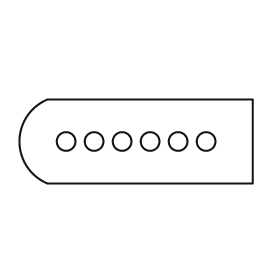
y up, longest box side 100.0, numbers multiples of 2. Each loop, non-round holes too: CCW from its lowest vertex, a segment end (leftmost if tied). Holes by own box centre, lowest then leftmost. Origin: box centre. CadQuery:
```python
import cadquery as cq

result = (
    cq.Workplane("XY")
    .moveTo(-38.0, -18.0)
    .lineTo(50.0, -18.0)
    .lineTo(50.0, 18.0)
    .lineTo(-38.0, 18.0)
    .threePointArc((-50.0, 0.0), (-38.0, -18.0))
    .close()
    .moveTo(-30.0, 0.0)
    .circle(4.0)
    .moveTo(-18.0, 0.0)
    .circle(4.0)
    .moveTo(-6.0, 0.0)
    .circle(4.0)
    .moveTo(6.0, 0.0)
    .circle(4.0)
    .moveTo(18.0, 0.0)
    .circle(4.0)
    .moveTo(30.0, 0.0)
    .circle(4.0)
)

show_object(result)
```